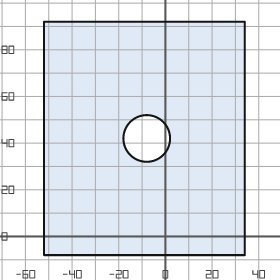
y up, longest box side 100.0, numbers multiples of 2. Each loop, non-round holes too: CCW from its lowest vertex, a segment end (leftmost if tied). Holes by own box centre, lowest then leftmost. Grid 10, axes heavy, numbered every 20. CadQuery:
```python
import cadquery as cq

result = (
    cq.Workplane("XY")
    .moveTo(-52.0, -8.0)
    .lineTo(34.0, -8.0)
    .lineTo(34.0, 92.0)
    .lineTo(-52.0, 92.0)
    .close()
    .moveTo(-8.0, 42.0)
    .circle(10.0)
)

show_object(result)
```